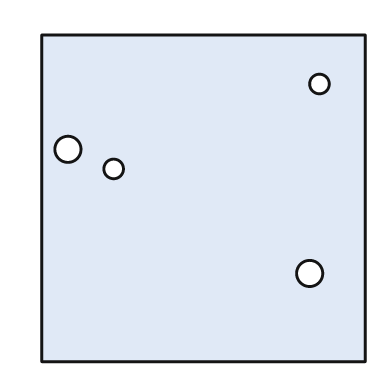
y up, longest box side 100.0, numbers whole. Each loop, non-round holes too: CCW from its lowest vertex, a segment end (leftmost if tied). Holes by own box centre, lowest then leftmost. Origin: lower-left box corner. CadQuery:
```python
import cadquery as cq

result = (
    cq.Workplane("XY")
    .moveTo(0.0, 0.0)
    .lineTo(99.0, 0.0)
    .lineTo(99.0, 100.0)
    .lineTo(0.0, 100.0)
    .close()
    .moveTo(82.0, 27.0)
    .circle(4.0)
    .moveTo(22.0, 59.0)
    .circle(3.0)
    .moveTo(8.0, 65.0)
    .circle(4.0)
    .moveTo(85.0, 85.0)
    .circle(3.0)
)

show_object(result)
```